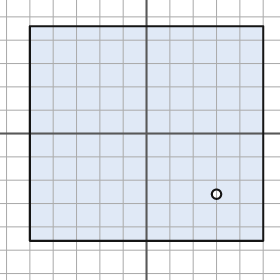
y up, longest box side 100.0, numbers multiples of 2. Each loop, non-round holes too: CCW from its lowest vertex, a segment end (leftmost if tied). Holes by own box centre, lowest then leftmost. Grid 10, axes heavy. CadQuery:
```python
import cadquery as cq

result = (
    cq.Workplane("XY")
    .moveTo(-50.0, -46.0)
    .lineTo(50.0, -46.0)
    .lineTo(50.0, 46.0)
    .lineTo(-50.0, 46.0)
    .close()
    .moveTo(30.0, -26.0)
    .circle(2.0)
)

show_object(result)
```